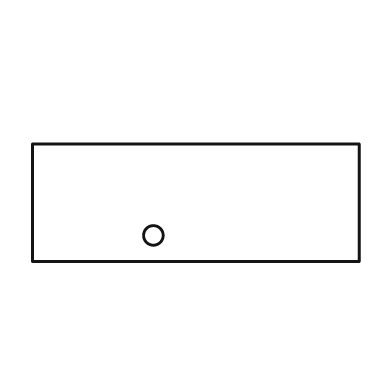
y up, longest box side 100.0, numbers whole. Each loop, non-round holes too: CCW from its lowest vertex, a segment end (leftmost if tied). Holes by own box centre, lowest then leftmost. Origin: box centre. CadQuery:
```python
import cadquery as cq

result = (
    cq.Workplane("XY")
    .moveTo(-50.0, -18.0)
    .lineTo(50.0, -18.0)
    .lineTo(50.0, 18.0)
    .lineTo(-50.0, 18.0)
    .close()
    .moveTo(-13.0, -10.0)
    .circle(3.0)
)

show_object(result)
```